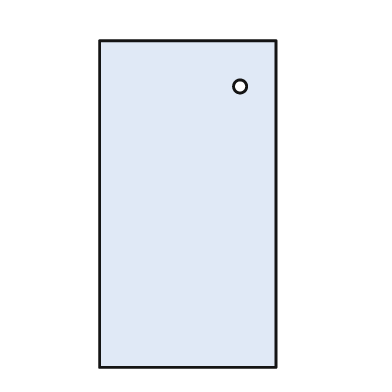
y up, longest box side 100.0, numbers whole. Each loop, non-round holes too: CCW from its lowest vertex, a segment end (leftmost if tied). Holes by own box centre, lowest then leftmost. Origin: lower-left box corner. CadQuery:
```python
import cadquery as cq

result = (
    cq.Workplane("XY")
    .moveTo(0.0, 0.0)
    .lineTo(54.0, 0.0)
    .lineTo(54.0, 100.0)
    .lineTo(0.0, 100.0)
    .close()
    .moveTo(43.0, 86.0)
    .circle(2.0)
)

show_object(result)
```